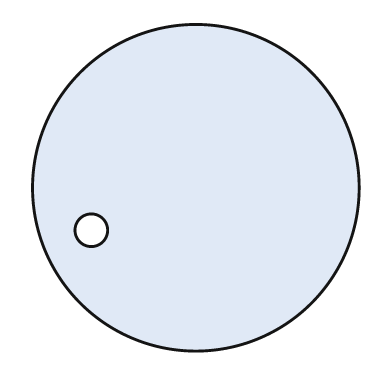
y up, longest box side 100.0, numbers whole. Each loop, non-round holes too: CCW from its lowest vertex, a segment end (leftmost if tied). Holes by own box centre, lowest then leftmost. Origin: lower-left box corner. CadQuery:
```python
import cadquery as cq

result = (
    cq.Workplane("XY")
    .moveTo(50.0, 50.0)
    .circle(50.0)
    .moveTo(18.0, 37.0)
    .circle(5.0)
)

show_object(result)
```